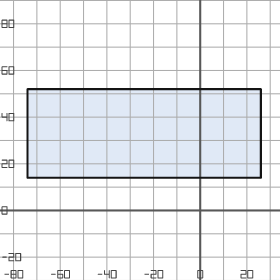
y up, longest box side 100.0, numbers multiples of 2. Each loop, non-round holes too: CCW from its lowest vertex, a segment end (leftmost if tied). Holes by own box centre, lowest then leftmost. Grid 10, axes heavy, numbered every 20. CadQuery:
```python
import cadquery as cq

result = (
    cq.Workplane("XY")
    .moveTo(-74.0, 14.0)
    .lineTo(26.0, 14.0)
    .lineTo(26.0, 52.0)
    .lineTo(-74.0, 52.0)
    .close()
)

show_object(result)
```